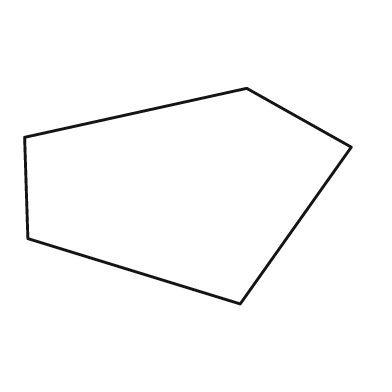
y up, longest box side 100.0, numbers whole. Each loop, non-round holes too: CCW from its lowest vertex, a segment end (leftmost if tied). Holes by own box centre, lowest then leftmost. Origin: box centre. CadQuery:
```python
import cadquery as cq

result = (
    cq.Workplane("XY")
    .moveTo(16.0, -33.0)
    .lineTo(50.0, 15.0)
    .lineTo(18.0, 33.0)
    .lineTo(-50.0, 18.0)
    .lineTo(-49.0, -13.0)
    .close()
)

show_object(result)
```